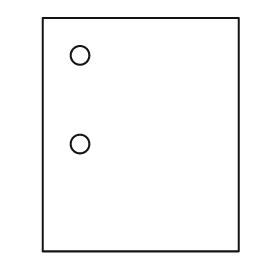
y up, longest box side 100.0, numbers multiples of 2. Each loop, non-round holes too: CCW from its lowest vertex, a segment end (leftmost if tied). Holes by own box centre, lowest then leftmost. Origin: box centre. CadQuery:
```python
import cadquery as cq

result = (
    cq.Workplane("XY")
    .moveTo(-42.0, -50.0)
    .lineTo(42.0, -50.0)
    .lineTo(42.0, 50.0)
    .lineTo(-42.0, 50.0)
    .close()
    .moveTo(-26.0, -4.0)
    .circle(4.0)
    .moveTo(-26.0, 34.0)
    .circle(4.0)
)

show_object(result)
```